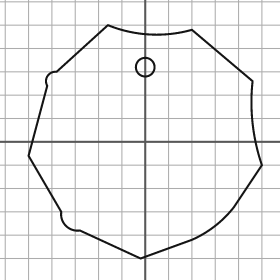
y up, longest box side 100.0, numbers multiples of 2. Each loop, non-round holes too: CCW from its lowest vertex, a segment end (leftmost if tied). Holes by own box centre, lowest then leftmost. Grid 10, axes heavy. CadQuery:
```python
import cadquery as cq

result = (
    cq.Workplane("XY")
    .moveTo(-2.0, -50.0)
    .lineTo(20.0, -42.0)
    .threePointArc((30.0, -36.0), (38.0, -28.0))
    .lineTo(50.0, -10.0)
    .threePointArc((46.0, 8.0), (46.0, 26.0))
    .lineTo(20.0, 48.0)
    .threePointArc((2.0, 46.0), (-16.0, 50.0))
    .lineTo(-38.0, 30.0)
    .threePointArc((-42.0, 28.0), (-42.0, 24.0))
    .lineTo(-50.0, -6.0)
    .lineTo(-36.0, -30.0)
    .threePointArc((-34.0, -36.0), (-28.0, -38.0))
    .close()
    .moveTo(0.0, 32.0)
    .circle(4.0)
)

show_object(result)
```